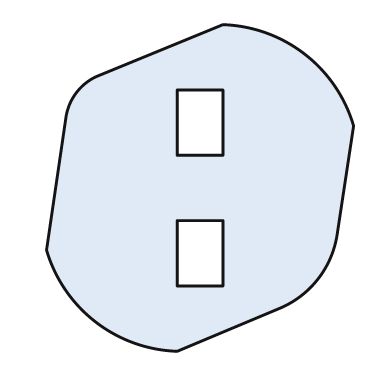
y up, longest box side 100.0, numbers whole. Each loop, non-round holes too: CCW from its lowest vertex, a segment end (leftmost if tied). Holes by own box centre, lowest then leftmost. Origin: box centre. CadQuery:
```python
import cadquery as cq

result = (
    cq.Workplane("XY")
    .moveTo(-7.0, -50.0)
    .lineTo(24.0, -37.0)
    .threePointArc((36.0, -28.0), (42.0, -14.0))
    .lineTo(47.0, 19.0)
    .threePointArc((32.0, 41.0), (7.0, 50.0))
    .lineTo(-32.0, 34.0)
    .threePointArc((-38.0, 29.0), (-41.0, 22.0))
    .lineTo(-47.0, -19.0)
    .threePointArc((-32.0, -41.0), (-7.0, -50.0))
    .close()
    .moveTo(-7.0, -30.0)
    .lineTo(7.0, -30.0)
    .lineTo(7.0, -10.0)
    .lineTo(-7.0, -10.0)
    .close()
    .moveTo(-7.0, 10.0)
    .lineTo(7.0, 10.0)
    .lineTo(7.0, 30.0)
    .lineTo(-7.0, 30.0)
    .close()
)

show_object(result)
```